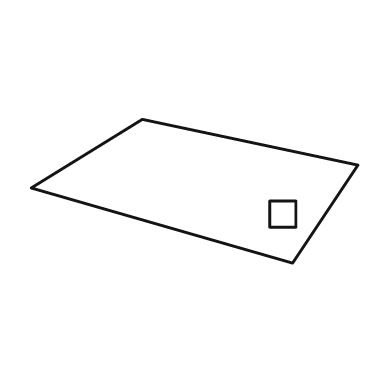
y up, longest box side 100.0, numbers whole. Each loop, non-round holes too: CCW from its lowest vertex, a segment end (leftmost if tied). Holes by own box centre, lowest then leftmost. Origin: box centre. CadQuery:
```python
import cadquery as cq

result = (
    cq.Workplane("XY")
    .moveTo(30.0, -22.0)
    .lineTo(50.0, 8.0)
    .lineTo(-16.0, 22.0)
    .lineTo(-50.0, 1.0)
    .close()
    .moveTo(23.0, -11.0)
    .lineTo(31.0, -11.0)
    .lineTo(31.0, -3.0)
    .lineTo(23.0, -3.0)
    .close()
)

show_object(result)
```